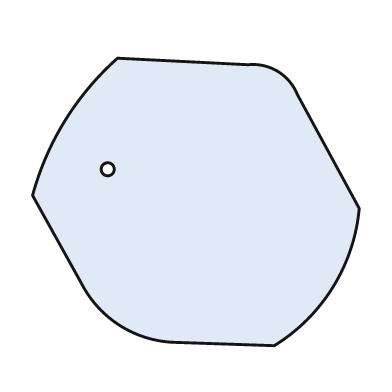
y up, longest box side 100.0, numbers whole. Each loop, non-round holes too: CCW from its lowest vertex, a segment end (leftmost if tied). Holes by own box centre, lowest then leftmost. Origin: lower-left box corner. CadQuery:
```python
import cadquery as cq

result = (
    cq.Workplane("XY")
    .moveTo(74.0, 0.0)
    .threePointArc((92.0, 18.0), (100.0, 42.0))
    .lineTo(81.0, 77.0)
    .threePointArc((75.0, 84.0), (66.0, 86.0))
    .lineTo(26.0, 88.0)
    .threePointArc((10.0, 69.0), (0.0, 46.0))
    .lineTo(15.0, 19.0)
    .threePointArc((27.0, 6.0), (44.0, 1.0))
    .close()
    .moveTo(23.0, 54.0)
    .circle(2.0)
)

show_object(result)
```